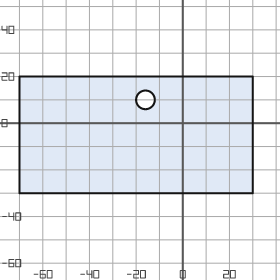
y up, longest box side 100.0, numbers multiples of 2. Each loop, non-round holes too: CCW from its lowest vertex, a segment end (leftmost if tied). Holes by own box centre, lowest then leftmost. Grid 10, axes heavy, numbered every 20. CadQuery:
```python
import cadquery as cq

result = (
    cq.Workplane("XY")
    .moveTo(-70.0, -30.0)
    .lineTo(30.0, -30.0)
    .lineTo(30.0, 20.0)
    .lineTo(-70.0, 20.0)
    .close()
    .moveTo(-16.0, 10.0)
    .circle(4.0)
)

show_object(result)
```